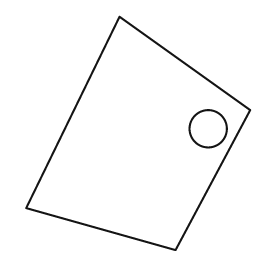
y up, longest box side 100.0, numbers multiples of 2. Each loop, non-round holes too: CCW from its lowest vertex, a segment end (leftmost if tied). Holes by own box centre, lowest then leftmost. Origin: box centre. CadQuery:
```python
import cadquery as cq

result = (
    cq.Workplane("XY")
    .moveTo(16.0, -50.0)
    .lineTo(48.0, 10.0)
    .lineTo(-8.0, 50.0)
    .lineTo(-48.0, -32.0)
    .close()
    .moveTo(30.0, 2.0)
    .circle(8.0)
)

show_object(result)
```